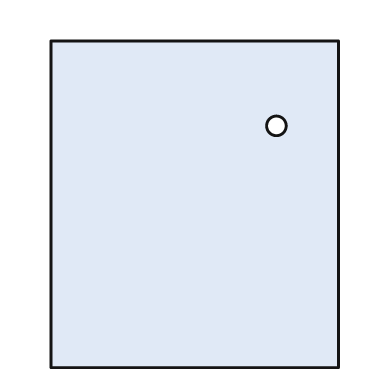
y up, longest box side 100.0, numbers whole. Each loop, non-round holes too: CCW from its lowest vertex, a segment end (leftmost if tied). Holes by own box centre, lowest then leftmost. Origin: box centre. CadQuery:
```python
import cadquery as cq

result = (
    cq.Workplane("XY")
    .moveTo(-44.0, -50.0)
    .lineTo(44.0, -50.0)
    .lineTo(44.0, 50.0)
    .lineTo(-44.0, 50.0)
    .close()
    .moveTo(25.0, 24.0)
    .circle(3.0)
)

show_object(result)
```